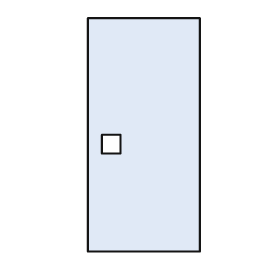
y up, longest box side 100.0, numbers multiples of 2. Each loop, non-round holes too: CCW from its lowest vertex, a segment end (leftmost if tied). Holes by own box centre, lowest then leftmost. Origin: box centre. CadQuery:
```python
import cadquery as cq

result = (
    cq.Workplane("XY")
    .moveTo(-24.0, -50.0)
    .lineTo(24.0, -50.0)
    .lineTo(24.0, 50.0)
    .lineTo(-24.0, 50.0)
    .close()
    .moveTo(-18.0, -8.0)
    .lineTo(-10.0, -8.0)
    .lineTo(-10.0, 0.0)
    .lineTo(-18.0, 0.0)
    .close()
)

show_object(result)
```